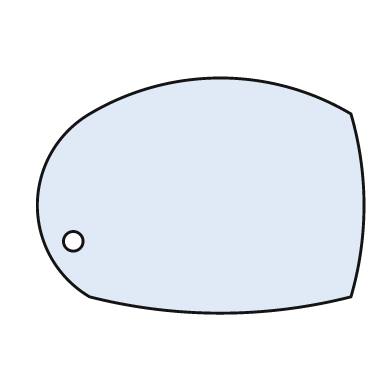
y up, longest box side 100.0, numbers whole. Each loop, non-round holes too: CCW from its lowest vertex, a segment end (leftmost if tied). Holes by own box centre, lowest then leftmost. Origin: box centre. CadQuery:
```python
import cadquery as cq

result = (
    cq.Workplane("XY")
    .moveTo(-34.0, -31.0)
    .threePointArc((6.0, -36.0), (46.0, -31.0))
    .threePointArc((50.0, -3.0), (46.0, 25.0))
    .threePointArc((6.0, 36.0), (-34.0, 25.0))
    .threePointArc((-50.0, -3.0), (-34.0, -31.0))
    .close()
    .moveTo(-39.0, -14.0)
    .circle(3.0)
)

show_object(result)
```